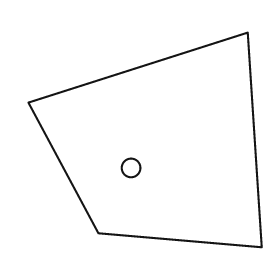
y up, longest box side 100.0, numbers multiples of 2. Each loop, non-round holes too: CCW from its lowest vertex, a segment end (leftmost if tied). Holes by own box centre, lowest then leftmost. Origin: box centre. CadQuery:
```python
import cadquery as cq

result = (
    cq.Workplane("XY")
    .moveTo(50.0, -46.0)
    .lineTo(44.0, 46.0)
    .lineTo(-50.0, 16.0)
    .lineTo(-20.0, -40.0)
    .close()
    .moveTo(-6.0, -12.0)
    .circle(4.0)
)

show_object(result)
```